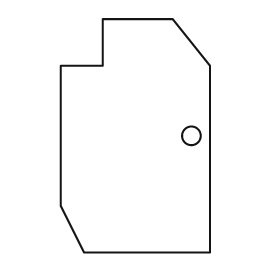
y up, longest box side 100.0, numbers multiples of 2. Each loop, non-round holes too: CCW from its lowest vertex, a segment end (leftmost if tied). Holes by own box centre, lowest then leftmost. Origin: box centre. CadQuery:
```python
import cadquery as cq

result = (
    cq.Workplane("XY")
    .moveTo(-22.0, -50.0)
    .lineTo(32.0, -50.0)
    .lineTo(32.0, 30.0)
    .lineTo(16.0, 50.0)
    .lineTo(-14.0, 50.0)
    .lineTo(-14.0, 30.0)
    .lineTo(-32.0, 30.0)
    .lineTo(-32.0, -30.0)
    .close()
    .moveTo(24.0, 0.0)
    .circle(4.0)
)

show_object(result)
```